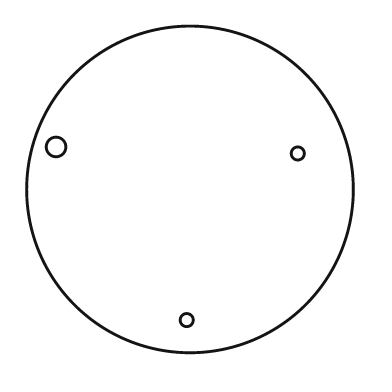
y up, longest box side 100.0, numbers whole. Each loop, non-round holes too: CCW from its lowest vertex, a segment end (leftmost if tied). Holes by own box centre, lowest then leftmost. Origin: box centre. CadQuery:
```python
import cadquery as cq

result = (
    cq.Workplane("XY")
    .moveTo(0.0, 0.0)
    .circle(50.0)
    .moveTo(-1.0, -40.0)
    .circle(2.0)
    .moveTo(33.0, 11.0)
    .circle(2.0)
    .moveTo(-41.0, 13.0)
    .circle(3.0)
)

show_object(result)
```